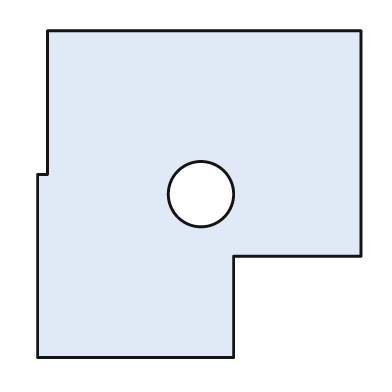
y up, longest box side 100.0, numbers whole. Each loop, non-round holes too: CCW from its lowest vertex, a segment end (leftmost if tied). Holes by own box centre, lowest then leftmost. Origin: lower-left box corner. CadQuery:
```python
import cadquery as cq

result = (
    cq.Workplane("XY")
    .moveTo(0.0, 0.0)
    .lineTo(60.0, 0.0)
    .lineTo(60.0, 31.0)
    .lineTo(99.0, 31.0)
    .lineTo(99.0, 100.0)
    .lineTo(3.0, 100.0)
    .lineTo(3.0, 56.0)
    .lineTo(0.0, 56.0)
    .close()
    .moveTo(50.0, 50.0)
    .circle(10.0)
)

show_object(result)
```